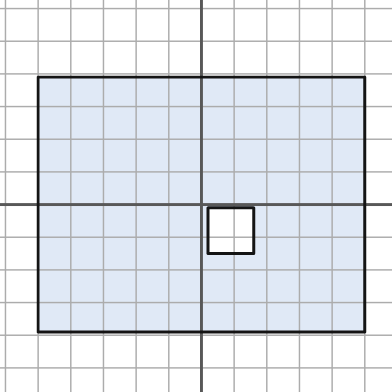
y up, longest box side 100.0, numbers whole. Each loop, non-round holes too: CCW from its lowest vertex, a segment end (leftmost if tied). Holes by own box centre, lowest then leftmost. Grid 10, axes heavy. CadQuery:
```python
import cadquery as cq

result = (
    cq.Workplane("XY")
    .moveTo(-50.0, -39.0)
    .lineTo(50.0, -39.0)
    .lineTo(50.0, 39.0)
    .lineTo(-50.0, 39.0)
    .close()
    .moveTo(2.0, -15.0)
    .lineTo(16.0, -15.0)
    .lineTo(16.0, -1.0)
    .lineTo(2.0, -1.0)
    .close()
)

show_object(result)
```